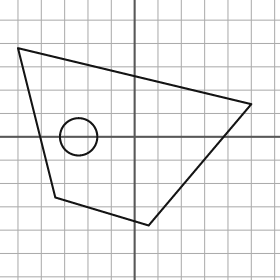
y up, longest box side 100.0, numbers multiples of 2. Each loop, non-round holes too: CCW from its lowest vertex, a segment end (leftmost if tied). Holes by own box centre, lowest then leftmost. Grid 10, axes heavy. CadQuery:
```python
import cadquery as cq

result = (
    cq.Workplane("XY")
    .moveTo(6.0, -38.0)
    .lineTo(50.0, 14.0)
    .lineTo(-50.0, 38.0)
    .lineTo(-34.0, -26.0)
    .close()
    .moveTo(-24.0, 0.0)
    .circle(8.0)
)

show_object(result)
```